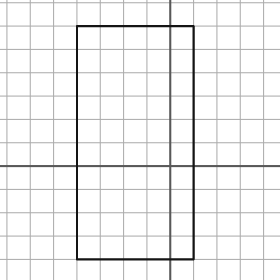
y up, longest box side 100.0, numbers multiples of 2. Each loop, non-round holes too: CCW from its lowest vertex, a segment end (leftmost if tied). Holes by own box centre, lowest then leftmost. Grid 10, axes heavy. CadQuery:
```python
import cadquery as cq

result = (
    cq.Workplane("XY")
    .moveTo(-40.0, -40.0)
    .lineTo(10.0, -40.0)
    .lineTo(10.0, 60.0)
    .lineTo(-40.0, 60.0)
    .close()
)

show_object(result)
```